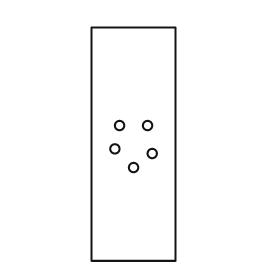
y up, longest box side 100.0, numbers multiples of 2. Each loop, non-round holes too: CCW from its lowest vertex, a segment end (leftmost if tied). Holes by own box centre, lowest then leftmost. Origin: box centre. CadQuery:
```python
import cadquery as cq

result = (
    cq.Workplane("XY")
    .moveTo(-18.0, -50.0)
    .lineTo(18.0, -50.0)
    .lineTo(18.0, 50.0)
    .lineTo(-18.0, 50.0)
    .close()
    .moveTo(0.0, -10.0)
    .circle(2.0)
    .moveTo(8.0, -4.0)
    .circle(2.0)
    .moveTo(-8.0, -2.0)
    .circle(2.0)
    .moveTo(-6.0, 8.0)
    .circle(2.0)
    .moveTo(6.0, 8.0)
    .circle(2.0)
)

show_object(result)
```